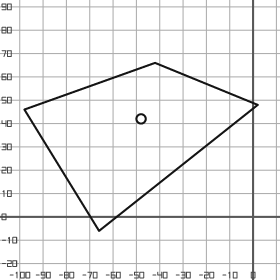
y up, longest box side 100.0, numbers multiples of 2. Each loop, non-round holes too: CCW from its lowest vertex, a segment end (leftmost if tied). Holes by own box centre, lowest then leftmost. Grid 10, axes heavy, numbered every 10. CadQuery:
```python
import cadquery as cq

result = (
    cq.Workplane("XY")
    .moveTo(-66.0, -6.0)
    .lineTo(2.0, 48.0)
    .lineTo(-42.0, 66.0)
    .lineTo(-98.0, 46.0)
    .close()
    .moveTo(-48.0, 42.0)
    .circle(2.0)
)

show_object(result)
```